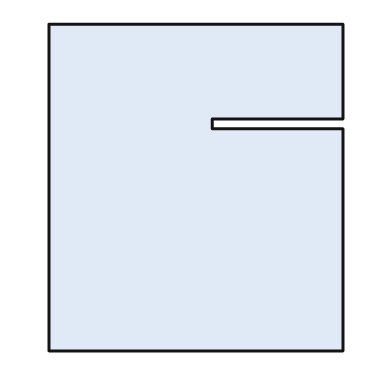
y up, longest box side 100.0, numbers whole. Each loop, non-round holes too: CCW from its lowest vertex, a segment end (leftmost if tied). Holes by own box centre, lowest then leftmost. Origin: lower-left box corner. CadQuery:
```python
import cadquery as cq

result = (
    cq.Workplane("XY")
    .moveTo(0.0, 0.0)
    .lineTo(90.0, 0.0)
    .lineTo(90.0, 68.0)
    .lineTo(50.0, 68.0)
    .lineTo(50.0, 71.0)
    .lineTo(90.0, 71.0)
    .lineTo(90.0, 100.0)
    .lineTo(0.0, 100.0)
    .close()
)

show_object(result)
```